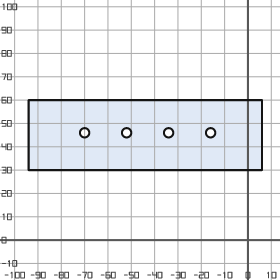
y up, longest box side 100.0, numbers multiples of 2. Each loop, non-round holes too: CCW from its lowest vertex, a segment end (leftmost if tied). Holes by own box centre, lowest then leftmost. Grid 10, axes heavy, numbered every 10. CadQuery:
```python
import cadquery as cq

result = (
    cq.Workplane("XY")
    .moveTo(-94.0, 30.0)
    .lineTo(6.0, 30.0)
    .lineTo(6.0, 60.0)
    .lineTo(-94.0, 60.0)
    .close()
    .moveTo(-70.0, 46.0)
    .circle(2.0)
    .moveTo(-52.0, 46.0)
    .circle(2.0)
    .moveTo(-34.0, 46.0)
    .circle(2.0)
    .moveTo(-16.0, 46.0)
    .circle(2.0)
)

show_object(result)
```